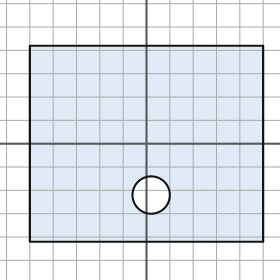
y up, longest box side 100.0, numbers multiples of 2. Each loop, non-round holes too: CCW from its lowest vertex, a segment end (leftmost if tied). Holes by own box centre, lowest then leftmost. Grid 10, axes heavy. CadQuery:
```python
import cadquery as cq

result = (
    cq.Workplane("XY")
    .moveTo(-50.0, -42.0)
    .lineTo(50.0, -42.0)
    .lineTo(50.0, 42.0)
    .lineTo(-50.0, 42.0)
    .close()
    .moveTo(2.0, -22.0)
    .circle(8.0)
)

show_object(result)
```